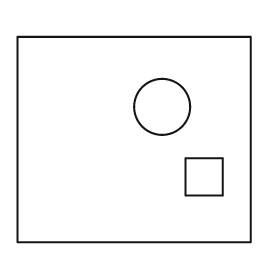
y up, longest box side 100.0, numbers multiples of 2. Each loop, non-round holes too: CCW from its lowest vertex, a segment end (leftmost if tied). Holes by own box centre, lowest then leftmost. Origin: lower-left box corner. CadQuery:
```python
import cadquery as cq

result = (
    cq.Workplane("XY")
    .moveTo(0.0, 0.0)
    .lineTo(100.0, 0.0)
    .lineTo(100.0, 88.0)
    .lineTo(0.0, 88.0)
    .close()
    .moveTo(72.0, 20.0)
    .lineTo(88.0, 20.0)
    .lineTo(88.0, 36.0)
    .lineTo(72.0, 36.0)
    .close()
    .moveTo(62.0, 58.0)
    .circle(12.0)
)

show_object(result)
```